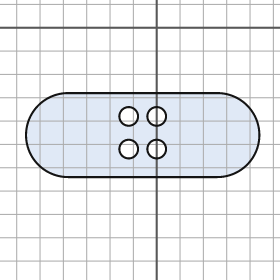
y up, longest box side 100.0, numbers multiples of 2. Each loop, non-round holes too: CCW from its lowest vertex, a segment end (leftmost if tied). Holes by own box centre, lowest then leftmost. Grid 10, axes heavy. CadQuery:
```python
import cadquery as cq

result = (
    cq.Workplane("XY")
    .moveTo(-38.0, -64.0)
    .lineTo(26.0, -64.0)
    .threePointArc((44.0, -46.0), (26.0, -28.0))
    .lineTo(-38.0, -28.0)
    .threePointArc((-56.0, -46.0), (-38.0, -64.0))
    .close()
    .moveTo(-12.0, -52.0)
    .circle(4.0)
    .moveTo(0.0, -52.0)
    .circle(4.0)
    .moveTo(-12.0, -38.0)
    .circle(4.0)
    .moveTo(0.0, -38.0)
    .circle(4.0)
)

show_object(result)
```